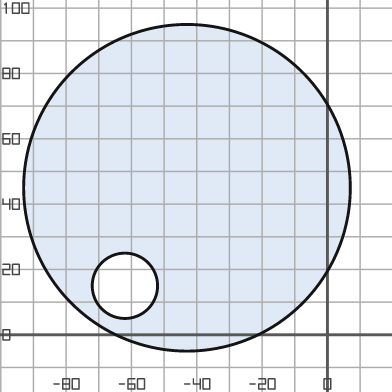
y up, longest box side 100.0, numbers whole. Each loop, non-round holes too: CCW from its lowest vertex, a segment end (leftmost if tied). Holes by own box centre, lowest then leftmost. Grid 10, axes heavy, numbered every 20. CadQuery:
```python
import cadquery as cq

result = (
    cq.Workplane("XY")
    .moveTo(-43.0, 45.0)
    .circle(50.0)
    .moveTo(-62.0, 15.0)
    .circle(10.0)
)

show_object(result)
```